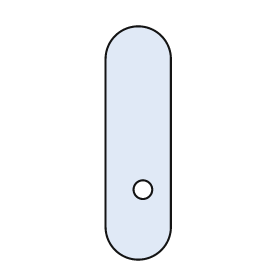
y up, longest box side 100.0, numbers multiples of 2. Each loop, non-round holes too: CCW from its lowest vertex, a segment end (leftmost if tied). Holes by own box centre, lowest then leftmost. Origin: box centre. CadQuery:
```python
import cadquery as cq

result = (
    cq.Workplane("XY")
    .moveTo(-14.0, -36.0)
    .threePointArc((0.0, -50.0), (14.0, -36.0))
    .lineTo(14.0, 36.0)
    .threePointArc((0.0, 50.0), (-14.0, 36.0))
    .close()
    .moveTo(2.0, -20.0)
    .circle(4.0)
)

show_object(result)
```